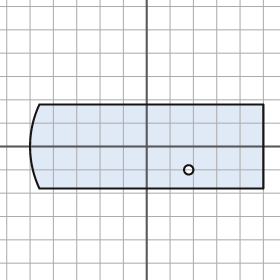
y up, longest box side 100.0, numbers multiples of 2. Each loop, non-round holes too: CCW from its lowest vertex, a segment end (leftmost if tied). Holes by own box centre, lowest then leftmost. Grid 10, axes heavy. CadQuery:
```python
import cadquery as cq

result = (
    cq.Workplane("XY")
    .moveTo(-46.0, -18.0)
    .lineTo(50.0, -18.0)
    .lineTo(50.0, 18.0)
    .lineTo(-46.0, 18.0)
    .threePointArc((-50.0, 0.0), (-46.0, -18.0))
    .close()
    .moveTo(18.0, -10.0)
    .circle(2.0)
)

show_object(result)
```